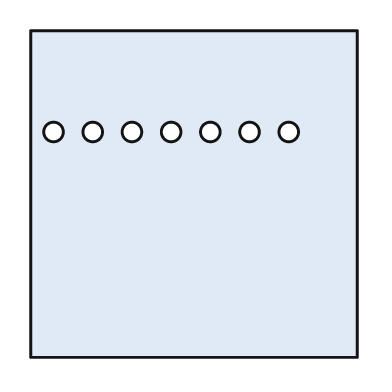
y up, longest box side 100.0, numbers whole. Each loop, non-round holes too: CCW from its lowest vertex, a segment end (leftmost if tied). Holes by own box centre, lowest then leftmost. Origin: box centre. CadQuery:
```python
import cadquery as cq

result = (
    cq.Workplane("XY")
    .moveTo(-50.0, -50.0)
    .lineTo(50.0, -50.0)
    .lineTo(50.0, 50.0)
    .lineTo(-50.0, 50.0)
    .close()
    .moveTo(-43.0, 19.0)
    .circle(3.0)
    .moveTo(-31.0, 19.0)
    .circle(3.0)
    .moveTo(-19.0, 19.0)
    .circle(3.0)
    .moveTo(-7.0, 19.0)
    .circle(3.0)
    .moveTo(5.0, 19.0)
    .circle(3.0)
    .moveTo(17.0, 19.0)
    .circle(3.0)
    .moveTo(29.0, 19.0)
    .circle(3.0)
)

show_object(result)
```